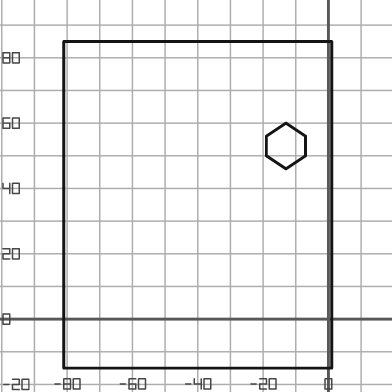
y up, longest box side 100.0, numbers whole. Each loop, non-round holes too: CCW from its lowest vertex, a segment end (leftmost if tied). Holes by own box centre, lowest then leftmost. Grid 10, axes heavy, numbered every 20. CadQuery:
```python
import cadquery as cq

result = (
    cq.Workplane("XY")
    .moveTo(-81.0, -15.0)
    .lineTo(1.0, -15.0)
    .lineTo(1.0, 85.0)
    .lineTo(-81.0, 85.0)
    .close()
    .moveTo(-13.0, 46.0)
    .lineTo(-7.0, 50.0)
    .lineTo(-7.0, 56.0)
    .lineTo(-13.0, 60.0)
    .lineTo(-19.0, 56.0)
    .lineTo(-19.0, 50.0)
    .close()
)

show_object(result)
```